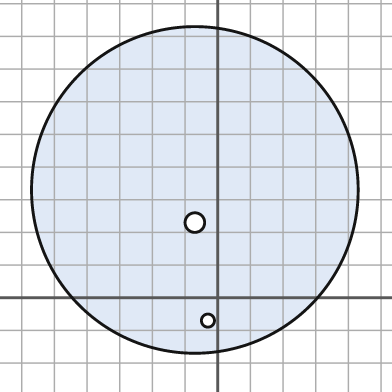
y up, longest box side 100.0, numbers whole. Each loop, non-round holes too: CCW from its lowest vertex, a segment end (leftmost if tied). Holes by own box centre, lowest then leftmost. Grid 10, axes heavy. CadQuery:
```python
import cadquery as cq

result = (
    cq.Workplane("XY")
    .moveTo(-7.0, 33.0)
    .circle(50.0)
    .moveTo(-3.0, -7.0)
    .circle(2.0)
    .moveTo(-7.0, 23.0)
    .circle(3.0)
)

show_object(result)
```